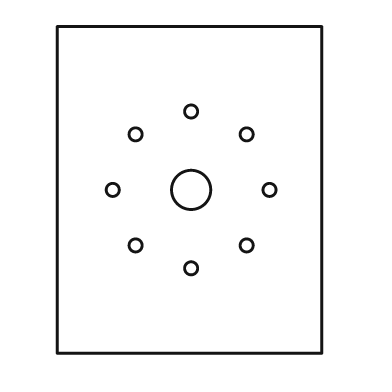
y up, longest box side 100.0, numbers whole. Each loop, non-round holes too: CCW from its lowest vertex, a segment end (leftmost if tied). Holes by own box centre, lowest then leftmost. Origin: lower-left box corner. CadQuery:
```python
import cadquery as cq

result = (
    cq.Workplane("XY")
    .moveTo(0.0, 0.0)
    .lineTo(81.0, 0.0)
    .lineTo(81.0, 100.0)
    .lineTo(0.0, 100.0)
    .close()
    .moveTo(41.0, 26.0)
    .circle(2.0)
    .moveTo(24.0, 33.0)
    .circle(2.0)
    .moveTo(58.0, 33.0)
    .circle(2.0)
    .moveTo(17.0, 50.0)
    .circle(2.0)
    .moveTo(41.0, 50.0)
    .circle(6.0)
    .moveTo(65.0, 50.0)
    .circle(2.0)
    .moveTo(24.0, 67.0)
    .circle(2.0)
    .moveTo(58.0, 67.0)
    .circle(2.0)
    .moveTo(41.0, 74.0)
    .circle(2.0)
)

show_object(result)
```